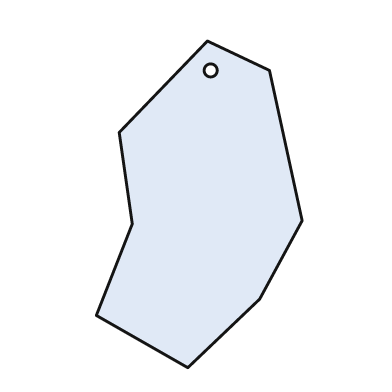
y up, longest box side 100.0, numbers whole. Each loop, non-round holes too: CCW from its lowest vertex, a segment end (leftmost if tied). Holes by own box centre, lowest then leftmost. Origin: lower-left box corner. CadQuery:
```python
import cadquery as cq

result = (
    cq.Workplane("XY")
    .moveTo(28.0, 0.0)
    .lineTo(50.0, 21.0)
    .lineTo(63.0, 45.0)
    .lineTo(53.0, 91.0)
    .lineTo(34.0, 100.0)
    .lineTo(7.0, 72.0)
    .lineTo(11.0, 44.0)
    .lineTo(0.0, 16.0)
    .close()
    .moveTo(35.0, 91.0)
    .circle(2.0)
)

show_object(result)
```